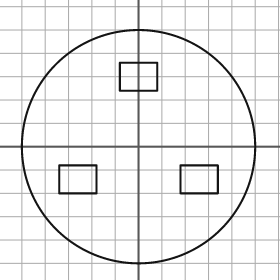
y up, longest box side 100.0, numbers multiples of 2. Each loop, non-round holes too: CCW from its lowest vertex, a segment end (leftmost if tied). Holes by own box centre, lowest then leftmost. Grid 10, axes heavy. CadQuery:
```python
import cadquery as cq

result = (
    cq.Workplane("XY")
    .moveTo(0.0, 0.0)
    .circle(50.0)
    .moveTo(-34.0, -20.0)
    .lineTo(-18.0, -20.0)
    .lineTo(-18.0, -8.0)
    .lineTo(-34.0, -8.0)
    .close()
    .moveTo(18.0, -20.0)
    .lineTo(34.0, -20.0)
    .lineTo(34.0, -8.0)
    .lineTo(18.0, -8.0)
    .close()
    .moveTo(-8.0, 24.0)
    .lineTo(8.0, 24.0)
    .lineTo(8.0, 36.0)
    .lineTo(-8.0, 36.0)
    .close()
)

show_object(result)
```